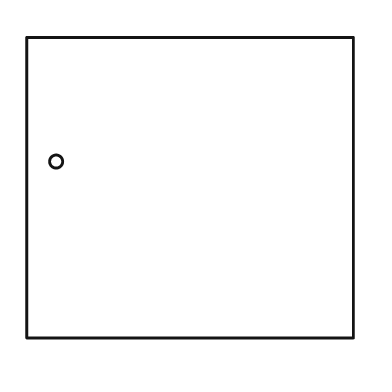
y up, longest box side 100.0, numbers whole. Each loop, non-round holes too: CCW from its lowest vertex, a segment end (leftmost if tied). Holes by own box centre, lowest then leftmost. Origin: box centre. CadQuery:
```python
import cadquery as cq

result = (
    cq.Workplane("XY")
    .moveTo(-50.0, -46.0)
    .lineTo(50.0, -46.0)
    .lineTo(50.0, 46.0)
    .lineTo(-50.0, 46.0)
    .close()
    .moveTo(-41.0, 8.0)
    .circle(2.0)
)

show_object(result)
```